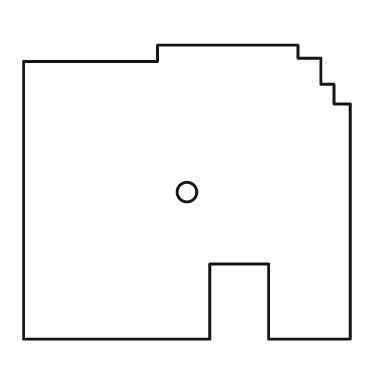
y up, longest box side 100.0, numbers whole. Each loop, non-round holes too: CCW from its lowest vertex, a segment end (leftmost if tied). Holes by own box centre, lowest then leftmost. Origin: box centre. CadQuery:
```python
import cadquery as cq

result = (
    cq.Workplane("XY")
    .moveTo(-50.0, -45.0)
    .lineTo(7.0, -45.0)
    .lineTo(7.0, -22.0)
    .lineTo(25.0, -22.0)
    .lineTo(25.0, -45.0)
    .lineTo(50.0, -45.0)
    .lineTo(50.0, 27.0)
    .lineTo(45.0, 27.0)
    .lineTo(45.0, 33.0)
    .lineTo(41.0, 33.0)
    .lineTo(41.0, 41.0)
    .lineTo(34.0, 41.0)
    .lineTo(34.0, 45.0)
    .lineTo(-9.0, 45.0)
    .lineTo(-9.0, 40.0)
    .lineTo(-50.0, 40.0)
    .close()
    .moveTo(0.0, 0.0)
    .circle(3.0)
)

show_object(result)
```